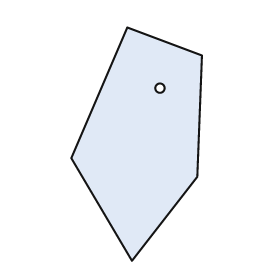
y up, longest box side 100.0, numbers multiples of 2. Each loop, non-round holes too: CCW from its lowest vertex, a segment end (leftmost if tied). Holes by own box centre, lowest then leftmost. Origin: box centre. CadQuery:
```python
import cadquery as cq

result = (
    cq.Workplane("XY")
    .moveTo(-2.0, -50.0)
    .lineTo(26.0, -14.0)
    .lineTo(28.0, 38.0)
    .lineTo(-4.0, 50.0)
    .lineTo(-28.0, -6.0)
    .close()
    .moveTo(10.0, 24.0)
    .circle(2.0)
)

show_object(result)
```